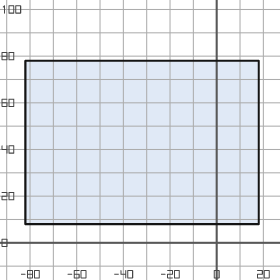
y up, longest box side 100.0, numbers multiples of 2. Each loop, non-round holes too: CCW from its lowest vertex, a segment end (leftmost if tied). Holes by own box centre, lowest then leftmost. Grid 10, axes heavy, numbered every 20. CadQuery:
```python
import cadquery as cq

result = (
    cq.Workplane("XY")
    .moveTo(-82.0, 8.0)
    .lineTo(18.0, 8.0)
    .lineTo(18.0, 78.0)
    .lineTo(-82.0, 78.0)
    .close()
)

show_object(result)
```